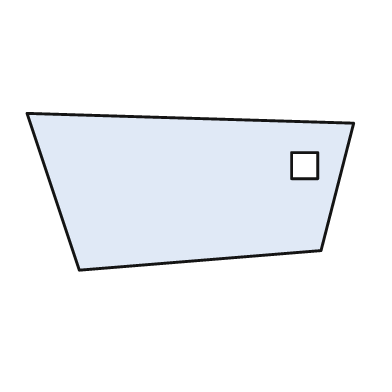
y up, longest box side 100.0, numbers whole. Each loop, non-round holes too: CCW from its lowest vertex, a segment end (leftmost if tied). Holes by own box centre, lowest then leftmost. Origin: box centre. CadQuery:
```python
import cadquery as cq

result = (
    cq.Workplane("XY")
    .moveTo(-34.0, -24.0)
    .lineTo(40.0, -18.0)
    .lineTo(50.0, 21.0)
    .lineTo(-50.0, 24.0)
    .close()
    .moveTo(31.0, 4.0)
    .lineTo(39.0, 4.0)
    .lineTo(39.0, 12.0)
    .lineTo(31.0, 12.0)
    .close()
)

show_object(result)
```